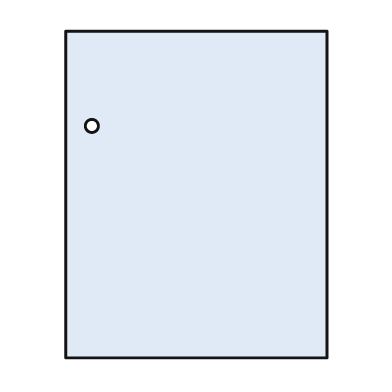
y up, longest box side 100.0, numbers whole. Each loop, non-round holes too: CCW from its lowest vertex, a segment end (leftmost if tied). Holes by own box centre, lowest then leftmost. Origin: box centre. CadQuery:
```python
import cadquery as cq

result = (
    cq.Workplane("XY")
    .moveTo(-40.0, -50.0)
    .lineTo(40.0, -50.0)
    .lineTo(40.0, 50.0)
    .lineTo(-40.0, 50.0)
    .close()
    .moveTo(-32.0, 21.0)
    .circle(2.0)
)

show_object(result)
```